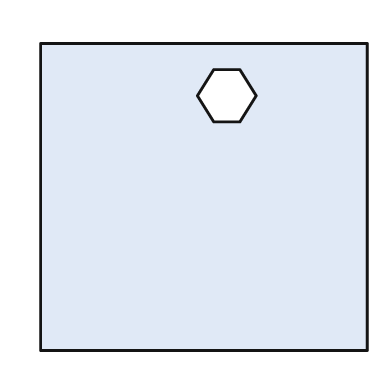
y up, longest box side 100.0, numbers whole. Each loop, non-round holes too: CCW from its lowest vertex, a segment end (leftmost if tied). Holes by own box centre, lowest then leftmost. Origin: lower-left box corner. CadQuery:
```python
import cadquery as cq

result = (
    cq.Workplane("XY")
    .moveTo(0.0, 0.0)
    .lineTo(100.0, 0.0)
    .lineTo(100.0, 94.0)
    .lineTo(0.0, 94.0)
    .close()
    .moveTo(53.0, 70.0)
    .lineTo(61.0, 70.0)
    .lineTo(66.0, 78.0)
    .lineTo(61.0, 86.0)
    .lineTo(53.0, 86.0)
    .lineTo(48.0, 78.0)
    .close()
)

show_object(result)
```